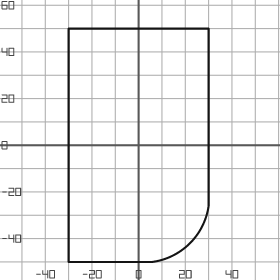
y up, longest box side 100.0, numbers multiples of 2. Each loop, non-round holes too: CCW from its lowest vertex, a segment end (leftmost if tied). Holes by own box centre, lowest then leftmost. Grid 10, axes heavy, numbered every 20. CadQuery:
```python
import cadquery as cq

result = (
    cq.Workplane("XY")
    .moveTo(-30.0, -50.0)
    .lineTo(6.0, -50.0)
    .threePointArc((22.0, -42.0), (30.0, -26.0))
    .lineTo(30.0, 50.0)
    .lineTo(-30.0, 50.0)
    .close()
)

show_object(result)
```